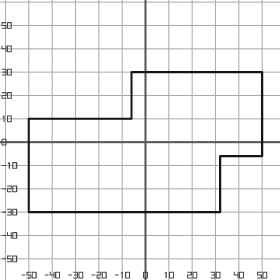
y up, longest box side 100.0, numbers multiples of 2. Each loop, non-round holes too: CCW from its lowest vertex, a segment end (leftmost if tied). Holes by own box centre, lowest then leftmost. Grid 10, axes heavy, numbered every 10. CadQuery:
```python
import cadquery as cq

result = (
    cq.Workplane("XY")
    .moveTo(-50.0, -30.0)
    .lineTo(32.0, -30.0)
    .lineTo(32.0, -6.0)
    .lineTo(50.0, -6.0)
    .lineTo(50.0, 30.0)
    .lineTo(-6.0, 30.0)
    .lineTo(-6.0, 10.0)
    .lineTo(-50.0, 10.0)
    .close()
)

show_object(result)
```